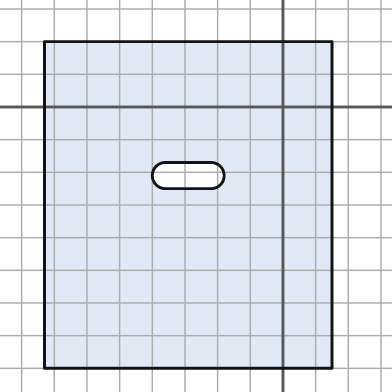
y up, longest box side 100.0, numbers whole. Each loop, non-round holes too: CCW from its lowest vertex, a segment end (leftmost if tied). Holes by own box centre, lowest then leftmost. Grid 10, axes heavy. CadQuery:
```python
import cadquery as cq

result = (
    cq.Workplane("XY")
    .moveTo(-73.0, -80.0)
    .lineTo(15.0, -80.0)
    .lineTo(15.0, 20.0)
    .lineTo(-73.0, 20.0)
    .close()
    .moveTo(-36.0, -25.0)
    .lineTo(-22.0, -25.0)
    .threePointArc((-18.0, -21.0), (-22.0, -17.0))
    .lineTo(-36.0, -17.0)
    .threePointArc((-40.0, -21.0), (-36.0, -25.0))
    .close()
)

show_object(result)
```